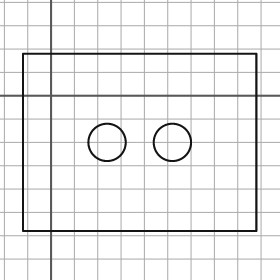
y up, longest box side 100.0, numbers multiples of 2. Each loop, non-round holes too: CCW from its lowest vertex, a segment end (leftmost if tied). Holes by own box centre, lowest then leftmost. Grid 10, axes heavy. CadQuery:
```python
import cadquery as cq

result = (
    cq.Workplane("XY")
    .moveTo(-12.0, -58.0)
    .lineTo(88.0, -58.0)
    .lineTo(88.0, 18.0)
    .lineTo(-12.0, 18.0)
    .close()
    .moveTo(24.0, -20.0)
    .circle(8.0)
    .moveTo(52.0, -20.0)
    .circle(8.0)
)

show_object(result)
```